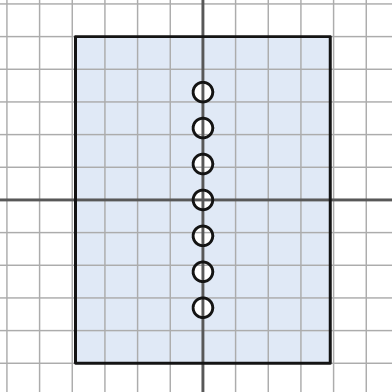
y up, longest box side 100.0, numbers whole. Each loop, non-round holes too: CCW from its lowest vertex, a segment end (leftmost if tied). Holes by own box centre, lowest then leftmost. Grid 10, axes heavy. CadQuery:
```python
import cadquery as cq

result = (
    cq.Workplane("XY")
    .moveTo(-39.0, -50.0)
    .lineTo(39.0, -50.0)
    .lineTo(39.0, 50.0)
    .lineTo(-39.0, 50.0)
    .close()
    .moveTo(0.0, -33.0)
    .circle(3.0)
    .moveTo(0.0, -22.0)
    .circle(3.0)
    .moveTo(0.0, -11.0)
    .circle(3.0)
    .moveTo(0.0, 0.0)
    .circle(3.0)
    .moveTo(0.0, 11.0)
    .circle(3.0)
    .moveTo(0.0, 22.0)
    .circle(3.0)
    .moveTo(0.0, 33.0)
    .circle(3.0)
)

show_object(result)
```